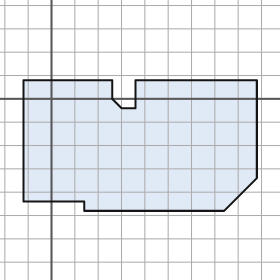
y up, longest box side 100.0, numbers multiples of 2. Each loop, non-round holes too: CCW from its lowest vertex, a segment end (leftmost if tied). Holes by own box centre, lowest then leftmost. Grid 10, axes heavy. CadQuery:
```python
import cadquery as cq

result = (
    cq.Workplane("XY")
    .moveTo(14.0, -48.0)
    .lineTo(74.0, -48.0)
    .lineTo(88.0, -34.0)
    .lineTo(88.0, 8.0)
    .lineTo(36.0, 8.0)
    .lineTo(36.0, -4.0)
    .lineTo(30.0, -4.0)
    .lineTo(26.0, 0.0)
    .lineTo(26.0, 8.0)
    .lineTo(-12.0, 8.0)
    .lineTo(-12.0, -44.0)
    .lineTo(14.0, -44.0)
    .close()
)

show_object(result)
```